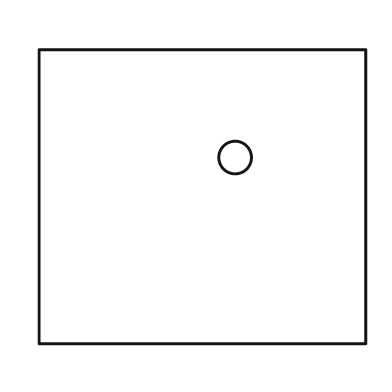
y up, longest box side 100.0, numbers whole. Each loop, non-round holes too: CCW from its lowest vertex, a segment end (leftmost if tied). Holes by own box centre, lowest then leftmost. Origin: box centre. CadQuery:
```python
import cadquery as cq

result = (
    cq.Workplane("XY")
    .moveTo(-50.0, -45.0)
    .lineTo(50.0, -45.0)
    .lineTo(50.0, 45.0)
    .lineTo(-50.0, 45.0)
    .close()
    .moveTo(10.0, 12.0)
    .circle(5.0)
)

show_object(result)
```